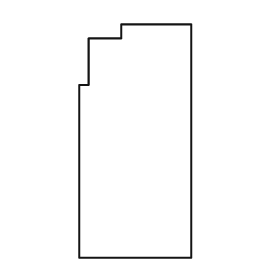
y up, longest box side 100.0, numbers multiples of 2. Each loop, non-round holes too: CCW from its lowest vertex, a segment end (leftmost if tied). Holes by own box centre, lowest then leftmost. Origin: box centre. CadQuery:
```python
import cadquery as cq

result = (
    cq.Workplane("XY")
    .moveTo(-24.0, -50.0)
    .lineTo(24.0, -50.0)
    .lineTo(24.0, 50.0)
    .lineTo(-6.0, 50.0)
    .lineTo(-6.0, 44.0)
    .lineTo(-20.0, 44.0)
    .lineTo(-20.0, 24.0)
    .lineTo(-24.0, 24.0)
    .close()
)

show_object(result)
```